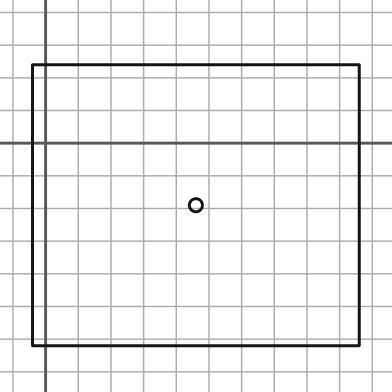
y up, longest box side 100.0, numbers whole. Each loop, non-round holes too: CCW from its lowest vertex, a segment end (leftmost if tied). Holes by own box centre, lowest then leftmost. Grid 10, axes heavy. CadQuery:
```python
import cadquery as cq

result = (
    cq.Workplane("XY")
    .moveTo(-4.0, -62.0)
    .lineTo(96.0, -62.0)
    .lineTo(96.0, 24.0)
    .lineTo(-4.0, 24.0)
    .close()
    .moveTo(46.0, -19.0)
    .circle(2.0)
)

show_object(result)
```